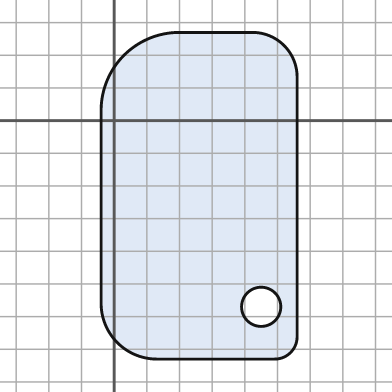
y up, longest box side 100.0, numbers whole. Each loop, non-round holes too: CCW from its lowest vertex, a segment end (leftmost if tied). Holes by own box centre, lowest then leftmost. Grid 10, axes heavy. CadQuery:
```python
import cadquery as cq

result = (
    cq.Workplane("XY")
    .moveTo(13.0, -73.0)
    .lineTo(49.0, -73.0)
    .threePointArc((54.0, -71.0), (56.0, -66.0))
    .lineTo(56.0, 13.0)
    .threePointArc((52.0, 23.0), (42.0, 27.0))
    .lineTo(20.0, 27.0)
    .threePointArc((3.0, 20.0), (-4.0, 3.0))
    .lineTo(-4.0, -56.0)
    .threePointArc((1.0, -68.0), (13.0, -73.0))
    .close()
    .moveTo(45.0, -57.0)
    .circle(6.0)
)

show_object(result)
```